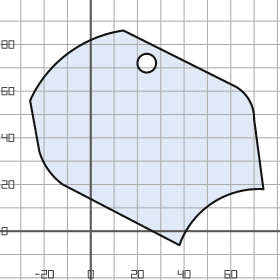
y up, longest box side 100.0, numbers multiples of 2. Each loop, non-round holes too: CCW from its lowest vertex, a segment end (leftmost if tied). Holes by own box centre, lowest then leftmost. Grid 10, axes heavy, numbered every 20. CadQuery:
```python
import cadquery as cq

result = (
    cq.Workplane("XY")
    .moveTo(38.0, -6.0)
    .threePointArc((52.0, 12.0), (74.0, 18.0))
    .lineTo(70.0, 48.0)
    .threePointArc((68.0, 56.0), (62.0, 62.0))
    .lineTo(14.0, 86.0)
    .threePointArc((-10.0, 76.0), (-26.0, 56.0))
    .lineTo(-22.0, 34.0)
    .threePointArc((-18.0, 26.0), (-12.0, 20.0))
    .close()
    .moveTo(24.0, 72.0)
    .circle(4.0)
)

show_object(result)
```